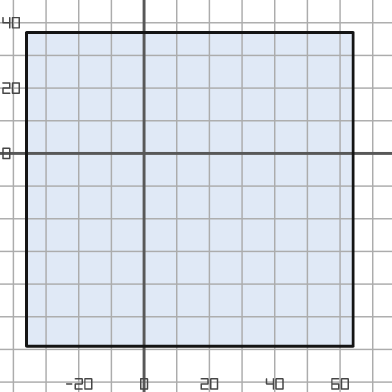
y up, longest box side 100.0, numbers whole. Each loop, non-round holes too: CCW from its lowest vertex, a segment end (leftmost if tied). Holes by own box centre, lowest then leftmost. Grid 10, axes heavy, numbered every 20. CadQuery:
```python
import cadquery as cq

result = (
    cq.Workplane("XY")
    .moveTo(-36.0, -59.0)
    .lineTo(64.0, -59.0)
    .lineTo(64.0, 37.0)
    .lineTo(-36.0, 37.0)
    .close()
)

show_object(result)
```